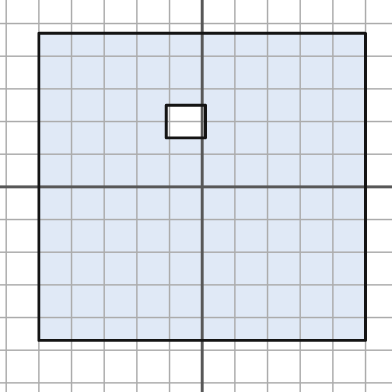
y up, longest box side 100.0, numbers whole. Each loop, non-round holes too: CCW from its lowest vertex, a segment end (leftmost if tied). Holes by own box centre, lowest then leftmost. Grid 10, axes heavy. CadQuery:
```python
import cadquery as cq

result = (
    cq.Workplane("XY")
    .moveTo(-50.0, -47.0)
    .lineTo(50.0, -47.0)
    .lineTo(50.0, 47.0)
    .lineTo(-50.0, 47.0)
    .close()
    .moveTo(-11.0, 15.0)
    .lineTo(1.0, 15.0)
    .lineTo(1.0, 25.0)
    .lineTo(-11.0, 25.0)
    .close()
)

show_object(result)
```